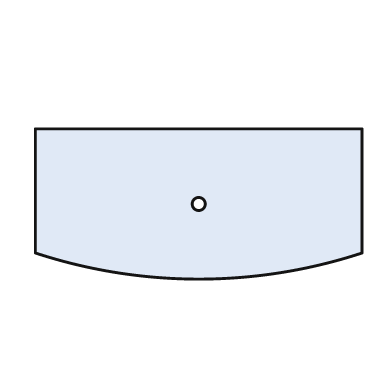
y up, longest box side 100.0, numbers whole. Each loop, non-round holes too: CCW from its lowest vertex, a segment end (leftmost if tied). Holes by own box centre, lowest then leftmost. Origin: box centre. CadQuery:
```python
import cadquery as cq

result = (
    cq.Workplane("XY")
    .moveTo(-50.0, -15.0)
    .threePointArc((0.0, -23.0), (50.0, -15.0))
    .lineTo(50.0, 23.0)
    .lineTo(-50.0, 23.0)
    .close()
    .moveTo(0.0, 0.0)
    .circle(2.0)
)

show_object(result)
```